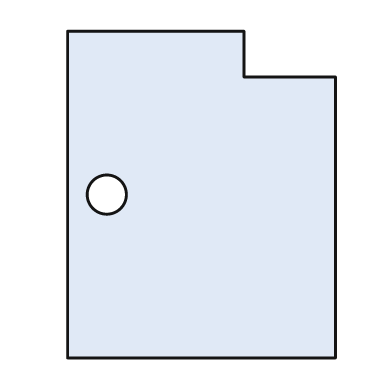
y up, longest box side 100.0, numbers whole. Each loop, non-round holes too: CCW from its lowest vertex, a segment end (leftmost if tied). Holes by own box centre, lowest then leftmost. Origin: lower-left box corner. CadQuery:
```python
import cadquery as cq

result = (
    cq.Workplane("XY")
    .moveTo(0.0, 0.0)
    .lineTo(82.0, 0.0)
    .lineTo(82.0, 86.0)
    .lineTo(54.0, 86.0)
    .lineTo(54.0, 100.0)
    .lineTo(0.0, 100.0)
    .close()
    .moveTo(12.0, 50.0)
    .circle(6.0)
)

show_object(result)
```